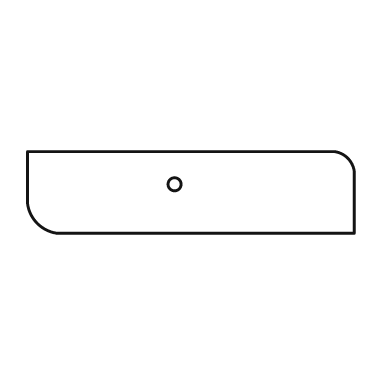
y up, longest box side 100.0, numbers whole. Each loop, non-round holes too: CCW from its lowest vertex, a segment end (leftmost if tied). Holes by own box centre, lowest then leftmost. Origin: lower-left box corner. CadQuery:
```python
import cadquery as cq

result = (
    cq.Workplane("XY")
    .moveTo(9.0, 0.0)
    .lineTo(100.0, 0.0)
    .lineTo(100.0, 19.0)
    .threePointArc((98.0, 23.0), (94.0, 25.0))
    .lineTo(0.0, 25.0)
    .lineTo(0.0, 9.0)
    .threePointArc((3.0, 3.0), (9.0, 0.0))
    .close()
    .moveTo(45.0, 15.0)
    .circle(2.0)
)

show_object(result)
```